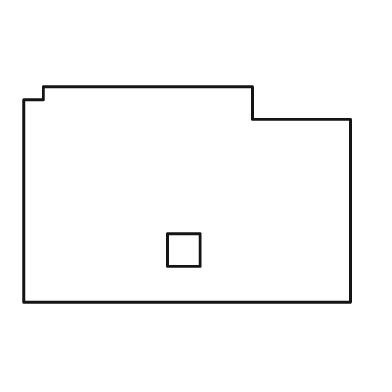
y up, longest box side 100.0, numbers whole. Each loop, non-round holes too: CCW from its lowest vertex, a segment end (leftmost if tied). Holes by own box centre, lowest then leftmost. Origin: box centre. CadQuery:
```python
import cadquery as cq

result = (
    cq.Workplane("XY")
    .moveTo(-50.0, -33.0)
    .lineTo(50.0, -33.0)
    .lineTo(50.0, 23.0)
    .lineTo(20.0, 23.0)
    .lineTo(20.0, 33.0)
    .lineTo(-44.0, 33.0)
    .lineTo(-44.0, 29.0)
    .lineTo(-50.0, 29.0)
    .close()
    .moveTo(-6.0, -22.0)
    .lineTo(4.0, -22.0)
    .lineTo(4.0, -12.0)
    .lineTo(-6.0, -12.0)
    .close()
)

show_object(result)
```